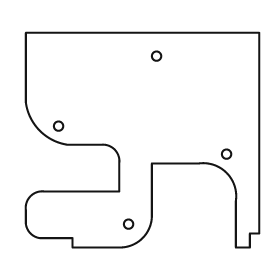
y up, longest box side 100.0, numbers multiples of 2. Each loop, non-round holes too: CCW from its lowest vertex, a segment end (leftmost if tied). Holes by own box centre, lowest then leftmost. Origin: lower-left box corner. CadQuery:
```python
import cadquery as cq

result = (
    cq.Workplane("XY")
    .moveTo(20.0, 0.0)
    .lineTo(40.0, 0.0)
    .threePointArc((50.0, 4.0), (54.0, 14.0))
    .lineTo(54.0, 36.0)
    .lineTo(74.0, 36.0)
    .threePointArc((86.0, 32.0), (90.0, 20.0))
    .lineTo(90.0, 0.0)
    .lineTo(96.0, 0.0)
    .lineTo(96.0, 6.0)
    .lineTo(100.0, 6.0)
    .lineTo(100.0, 92.0)
    .lineTo(0.0, 92.0)
    .lineTo(0.0, 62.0)
    .threePointArc((6.0, 50.0), (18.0, 44.0))
    .lineTo(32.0, 44.0)
    .threePointArc((38.0, 42.0), (40.0, 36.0))
    .lineTo(40.0, 24.0)
    .lineTo(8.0, 24.0)
    .threePointArc((2.0, 22.0), (0.0, 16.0))
    .lineTo(0.0, 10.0)
    .threePointArc((2.0, 6.0), (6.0, 4.0))
    .lineTo(20.0, 4.0)
    .close()
    .moveTo(44.0, 10.0)
    .circle(2.0)
    .moveTo(86.0, 40.0)
    .circle(2.0)
    .moveTo(14.0, 52.0)
    .circle(2.0)
    .moveTo(56.0, 82.0)
    .circle(2.0)
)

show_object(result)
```